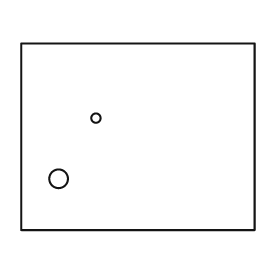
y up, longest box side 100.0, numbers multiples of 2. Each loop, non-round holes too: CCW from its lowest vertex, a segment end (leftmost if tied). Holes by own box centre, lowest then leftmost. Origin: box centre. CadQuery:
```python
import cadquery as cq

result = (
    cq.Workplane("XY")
    .moveTo(-50.0, -40.0)
    .lineTo(50.0, -40.0)
    .lineTo(50.0, 40.0)
    .lineTo(-50.0, 40.0)
    .close()
    .moveTo(-34.0, -18.0)
    .circle(4.0)
    .moveTo(-18.0, 8.0)
    .circle(2.0)
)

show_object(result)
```